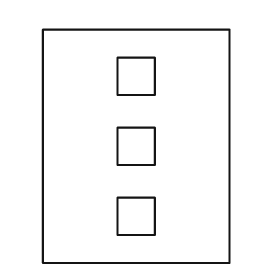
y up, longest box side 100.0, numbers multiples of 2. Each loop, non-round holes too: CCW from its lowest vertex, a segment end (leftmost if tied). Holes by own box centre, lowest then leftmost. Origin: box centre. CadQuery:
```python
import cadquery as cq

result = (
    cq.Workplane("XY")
    .moveTo(-40.0, -50.0)
    .lineTo(40.0, -50.0)
    .lineTo(40.0, 50.0)
    .lineTo(-40.0, 50.0)
    .close()
    .moveTo(-8.0, -38.0)
    .lineTo(8.0, -38.0)
    .lineTo(8.0, -22.0)
    .lineTo(-8.0, -22.0)
    .close()
    .moveTo(-8.0, -8.0)
    .lineTo(8.0, -8.0)
    .lineTo(8.0, 8.0)
    .lineTo(-8.0, 8.0)
    .close()
    .moveTo(-8.0, 22.0)
    .lineTo(8.0, 22.0)
    .lineTo(8.0, 38.0)
    .lineTo(-8.0, 38.0)
    .close()
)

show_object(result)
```